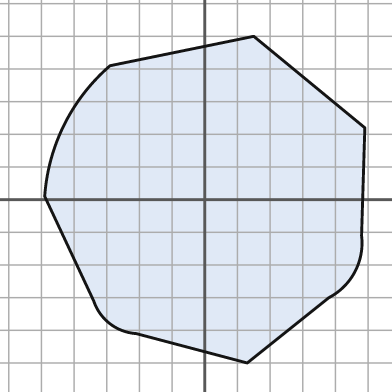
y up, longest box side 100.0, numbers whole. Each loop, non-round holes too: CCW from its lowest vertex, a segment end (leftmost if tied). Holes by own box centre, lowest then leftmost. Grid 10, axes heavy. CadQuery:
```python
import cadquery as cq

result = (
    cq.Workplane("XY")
    .moveTo(13.0, -50.0)
    .lineTo(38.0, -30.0)
    .threePointArc((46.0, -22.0), (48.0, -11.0))
    .lineTo(49.0, 22.0)
    .lineTo(15.0, 50.0)
    .lineTo(-29.0, 41.0)
    .threePointArc((-43.0, 23.0), (-49.0, 1.0))
    .lineTo(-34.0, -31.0)
    .threePointArc((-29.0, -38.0), (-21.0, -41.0))
    .close()
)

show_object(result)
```